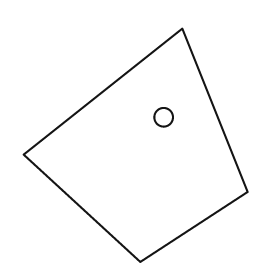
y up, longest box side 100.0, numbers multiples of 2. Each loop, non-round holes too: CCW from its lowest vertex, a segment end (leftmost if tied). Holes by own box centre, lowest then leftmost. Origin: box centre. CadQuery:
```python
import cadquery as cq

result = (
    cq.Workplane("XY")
    .moveTo(2.0, -50.0)
    .lineTo(48.0, -20.0)
    .lineTo(20.0, 50.0)
    .lineTo(-48.0, -4.0)
    .close()
    .moveTo(12.0, 12.0)
    .circle(4.0)
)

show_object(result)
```